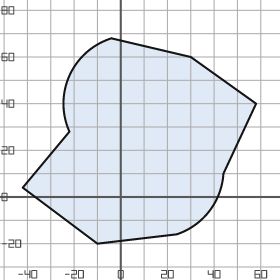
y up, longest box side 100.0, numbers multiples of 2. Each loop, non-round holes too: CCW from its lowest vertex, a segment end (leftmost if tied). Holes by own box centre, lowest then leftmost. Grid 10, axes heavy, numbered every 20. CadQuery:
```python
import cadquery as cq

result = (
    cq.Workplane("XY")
    .moveTo(-10.0, -20.0)
    .lineTo(24.0, -16.0)
    .threePointArc((38.0, -6.0), (44.0, 10.0))
    .lineTo(58.0, 40.0)
    .lineTo(30.0, 60.0)
    .lineTo(-4.0, 68.0)
    .threePointArc((-22.0, 52.0), (-22.0, 28.0))
    .lineTo(-42.0, 4.0)
    .close()
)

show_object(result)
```